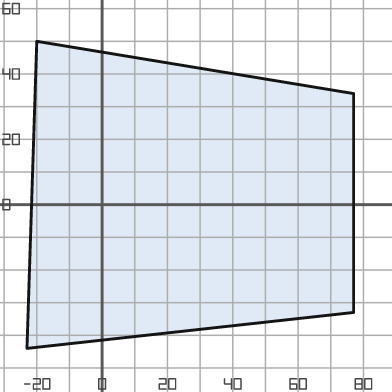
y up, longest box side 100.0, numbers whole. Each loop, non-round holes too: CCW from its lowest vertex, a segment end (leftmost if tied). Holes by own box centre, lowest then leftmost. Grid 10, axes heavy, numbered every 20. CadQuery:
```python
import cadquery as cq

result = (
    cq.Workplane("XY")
    .moveTo(-23.0, -44.0)
    .lineTo(77.0, -33.0)
    .lineTo(77.0, 34.0)
    .lineTo(-20.0, 50.0)
    .close()
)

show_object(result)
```